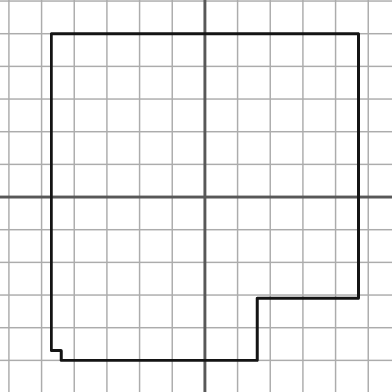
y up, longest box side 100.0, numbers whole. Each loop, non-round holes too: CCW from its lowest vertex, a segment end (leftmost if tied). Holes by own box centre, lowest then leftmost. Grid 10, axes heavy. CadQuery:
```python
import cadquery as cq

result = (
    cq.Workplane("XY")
    .moveTo(-44.0, -50.0)
    .lineTo(16.0, -50.0)
    .lineTo(16.0, -31.0)
    .lineTo(47.0, -31.0)
    .lineTo(47.0, 50.0)
    .lineTo(-47.0, 50.0)
    .lineTo(-47.0, -47.0)
    .lineTo(-44.0, -47.0)
    .close()
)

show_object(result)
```